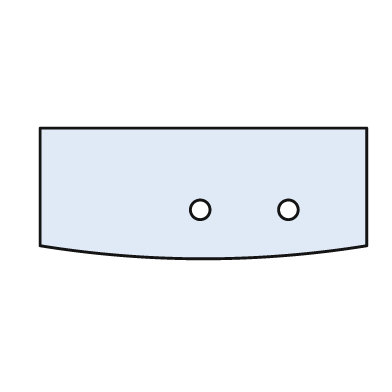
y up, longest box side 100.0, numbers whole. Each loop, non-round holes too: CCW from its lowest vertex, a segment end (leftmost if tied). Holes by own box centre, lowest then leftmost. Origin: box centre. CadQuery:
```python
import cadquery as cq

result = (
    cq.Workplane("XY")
    .moveTo(-50.0, -16.0)
    .threePointArc((0.0, -20.0), (50.0, -16.0))
    .lineTo(50.0, 20.0)
    .lineTo(-50.0, 20.0)
    .close()
    .moveTo(-1.0, -5.0)
    .circle(3.0)
    .moveTo(26.0, -5.0)
    .circle(3.0)
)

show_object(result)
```